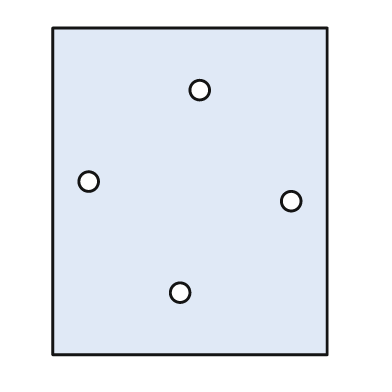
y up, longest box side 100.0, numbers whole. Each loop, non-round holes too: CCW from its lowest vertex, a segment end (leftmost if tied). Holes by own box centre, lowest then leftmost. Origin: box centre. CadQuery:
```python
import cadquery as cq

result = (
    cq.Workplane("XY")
    .moveTo(-42.0, -50.0)
    .lineTo(42.0, -50.0)
    .lineTo(42.0, 50.0)
    .lineTo(-42.0, 50.0)
    .close()
    .moveTo(-3.0, -31.0)
    .circle(3.0)
    .moveTo(31.0, -3.0)
    .circle(3.0)
    .moveTo(-31.0, 3.0)
    .circle(3.0)
    .moveTo(3.0, 31.0)
    .circle(3.0)
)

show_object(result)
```